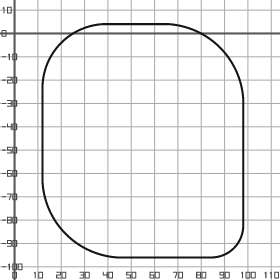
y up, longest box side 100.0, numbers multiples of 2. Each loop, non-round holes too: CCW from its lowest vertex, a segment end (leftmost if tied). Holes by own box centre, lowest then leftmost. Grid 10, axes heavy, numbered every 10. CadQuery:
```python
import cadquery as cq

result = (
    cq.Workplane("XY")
    .moveTo(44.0, -96.0)
    .lineTo(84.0, -96.0)
    .threePointArc((94.0, -92.0), (98.0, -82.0))
    .lineTo(98.0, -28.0)
    .threePointArc((88.0, -6.0), (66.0, 4.0))
    .lineTo(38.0, 4.0)
    .threePointArc((20.0, -4.0), (12.0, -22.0))
    .lineTo(12.0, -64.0)
    .threePointArc((22.0, -86.0), (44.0, -96.0))
    .close()
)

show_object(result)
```